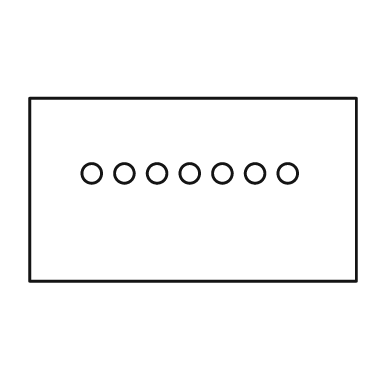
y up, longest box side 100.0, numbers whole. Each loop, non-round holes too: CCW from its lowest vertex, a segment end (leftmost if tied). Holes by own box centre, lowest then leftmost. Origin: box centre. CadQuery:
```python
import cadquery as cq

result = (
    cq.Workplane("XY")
    .moveTo(-50.0, -28.0)
    .lineTo(50.0, -28.0)
    .lineTo(50.0, 28.0)
    .lineTo(-50.0, 28.0)
    .close()
    .moveTo(-31.0, 5.0)
    .circle(3.0)
    .moveTo(-21.0, 5.0)
    .circle(3.0)
    .moveTo(-11.0, 5.0)
    .circle(3.0)
    .moveTo(-1.0, 5.0)
    .circle(3.0)
    .moveTo(9.0, 5.0)
    .circle(3.0)
    .moveTo(19.0, 5.0)
    .circle(3.0)
    .moveTo(29.0, 5.0)
    .circle(3.0)
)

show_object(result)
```